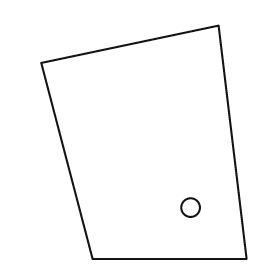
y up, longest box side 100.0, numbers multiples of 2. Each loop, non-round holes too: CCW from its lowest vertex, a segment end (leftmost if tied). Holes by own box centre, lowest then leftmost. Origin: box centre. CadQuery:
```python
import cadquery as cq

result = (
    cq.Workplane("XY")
    .moveTo(-22.0, -50.0)
    .lineTo(44.0, -50.0)
    .lineTo(32.0, 50.0)
    .lineTo(-44.0, 34.0)
    .close()
    .moveTo(20.0, -28.0)
    .circle(4.0)
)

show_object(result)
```